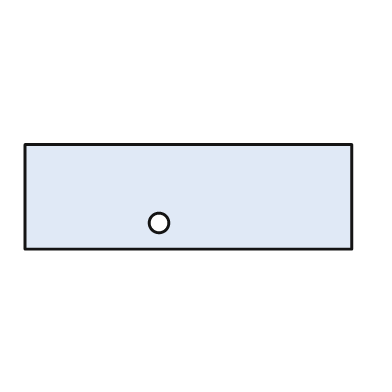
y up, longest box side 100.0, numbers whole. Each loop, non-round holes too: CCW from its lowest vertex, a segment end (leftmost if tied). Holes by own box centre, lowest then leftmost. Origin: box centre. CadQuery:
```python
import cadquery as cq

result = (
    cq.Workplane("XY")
    .moveTo(-50.0, -16.0)
    .lineTo(50.0, -16.0)
    .lineTo(50.0, 16.0)
    .lineTo(-50.0, 16.0)
    .close()
    .moveTo(-9.0, -8.0)
    .circle(3.0)
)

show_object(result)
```